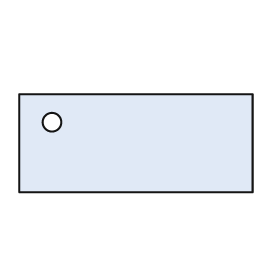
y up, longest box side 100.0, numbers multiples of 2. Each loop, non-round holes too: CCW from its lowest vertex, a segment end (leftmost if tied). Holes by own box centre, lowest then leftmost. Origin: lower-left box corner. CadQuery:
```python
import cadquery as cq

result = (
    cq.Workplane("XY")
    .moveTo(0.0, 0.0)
    .lineTo(100.0, 0.0)
    .lineTo(100.0, 42.0)
    .lineTo(0.0, 42.0)
    .close()
    .moveTo(14.0, 30.0)
    .circle(4.0)
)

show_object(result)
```